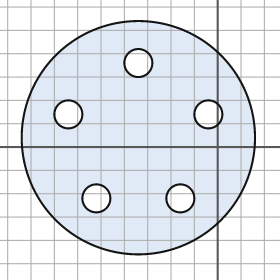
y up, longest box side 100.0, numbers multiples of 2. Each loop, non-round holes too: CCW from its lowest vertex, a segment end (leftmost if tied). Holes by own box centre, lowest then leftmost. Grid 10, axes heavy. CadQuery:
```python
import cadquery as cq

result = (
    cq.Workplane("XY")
    .moveTo(-34.0, 4.0)
    .circle(50.0)
    .moveTo(-52.0, -22.0)
    .circle(6.0)
    .moveTo(-16.0, -22.0)
    .circle(6.0)
    .moveTo(-64.0, 14.0)
    .circle(6.0)
    .moveTo(-4.0, 14.0)
    .circle(6.0)
    .moveTo(-34.0, 36.0)
    .circle(6.0)
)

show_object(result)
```